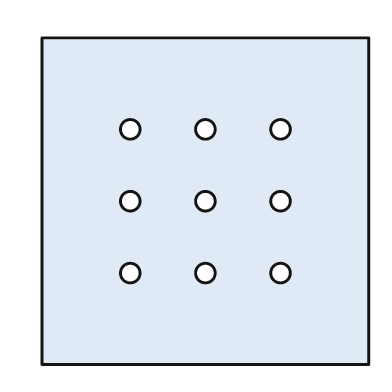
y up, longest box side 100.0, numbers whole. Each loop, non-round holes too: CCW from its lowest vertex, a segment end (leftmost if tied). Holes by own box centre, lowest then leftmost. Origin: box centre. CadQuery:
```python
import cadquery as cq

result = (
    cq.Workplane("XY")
    .moveTo(-50.0, -50.0)
    .lineTo(50.0, -50.0)
    .lineTo(50.0, 50.0)
    .lineTo(-50.0, 50.0)
    .close()
    .moveTo(-23.0, -22.0)
    .circle(3.0)
    .moveTo(0.0, -22.0)
    .circle(3.0)
    .moveTo(23.0, -22.0)
    .circle(3.0)
    .moveTo(-23.0, 0.0)
    .circle(3.0)
    .moveTo(0.0, 0.0)
    .circle(3.0)
    .moveTo(23.0, 0.0)
    .circle(3.0)
    .moveTo(-23.0, 22.0)
    .circle(3.0)
    .moveTo(0.0, 22.0)
    .circle(3.0)
    .moveTo(23.0, 22.0)
    .circle(3.0)
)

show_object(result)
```